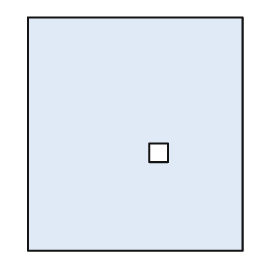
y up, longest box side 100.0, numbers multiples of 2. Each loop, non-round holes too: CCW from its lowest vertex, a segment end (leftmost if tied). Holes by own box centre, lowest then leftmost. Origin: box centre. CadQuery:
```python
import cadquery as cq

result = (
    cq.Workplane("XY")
    .moveTo(-46.0, -50.0)
    .lineTo(46.0, -50.0)
    .lineTo(46.0, 50.0)
    .lineTo(-46.0, 50.0)
    .close()
    .moveTo(6.0, -12.0)
    .lineTo(14.0, -12.0)
    .lineTo(14.0, -4.0)
    .lineTo(6.0, -4.0)
    .close()
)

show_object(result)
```